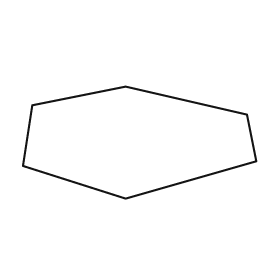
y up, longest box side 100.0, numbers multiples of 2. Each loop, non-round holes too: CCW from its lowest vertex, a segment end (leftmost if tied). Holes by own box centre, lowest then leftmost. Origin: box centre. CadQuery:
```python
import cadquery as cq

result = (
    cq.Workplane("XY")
    .moveTo(-6.0, -24.0)
    .lineTo(50.0, -8.0)
    .lineTo(46.0, 12.0)
    .lineTo(-6.0, 24.0)
    .lineTo(-46.0, 16.0)
    .lineTo(-50.0, -10.0)
    .close()
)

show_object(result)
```